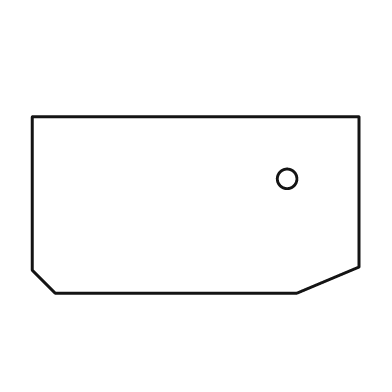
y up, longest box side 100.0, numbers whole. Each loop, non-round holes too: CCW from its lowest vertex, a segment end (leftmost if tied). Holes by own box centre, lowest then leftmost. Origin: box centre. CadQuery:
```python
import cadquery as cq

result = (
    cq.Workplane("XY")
    .moveTo(-43.0, -27.0)
    .lineTo(31.0, -27.0)
    .lineTo(50.0, -19.0)
    .lineTo(50.0, 27.0)
    .lineTo(-50.0, 27.0)
    .lineTo(-50.0, -20.0)
    .close()
    .moveTo(28.0, 8.0)
    .circle(3.0)
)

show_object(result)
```